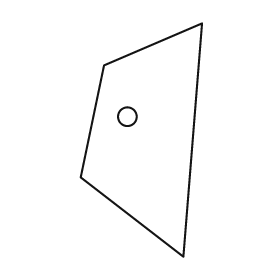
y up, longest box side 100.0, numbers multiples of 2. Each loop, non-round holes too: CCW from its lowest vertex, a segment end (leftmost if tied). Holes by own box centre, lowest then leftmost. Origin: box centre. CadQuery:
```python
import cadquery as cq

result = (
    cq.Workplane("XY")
    .moveTo(18.0, -50.0)
    .lineTo(26.0, 50.0)
    .lineTo(-16.0, 32.0)
    .lineTo(-26.0, -16.0)
    .close()
    .moveTo(-6.0, 10.0)
    .circle(4.0)
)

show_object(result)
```